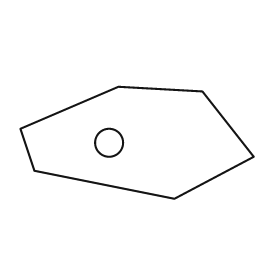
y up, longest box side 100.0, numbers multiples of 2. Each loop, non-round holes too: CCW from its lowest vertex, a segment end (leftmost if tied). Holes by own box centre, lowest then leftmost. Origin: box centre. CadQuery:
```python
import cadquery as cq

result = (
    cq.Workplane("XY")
    .moveTo(16.0, -24.0)
    .lineTo(50.0, -6.0)
    .lineTo(28.0, 22.0)
    .lineTo(-8.0, 24.0)
    .lineTo(-50.0, 6.0)
    .lineTo(-44.0, -12.0)
    .close()
    .moveTo(-12.0, 0.0)
    .circle(6.0)
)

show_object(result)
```